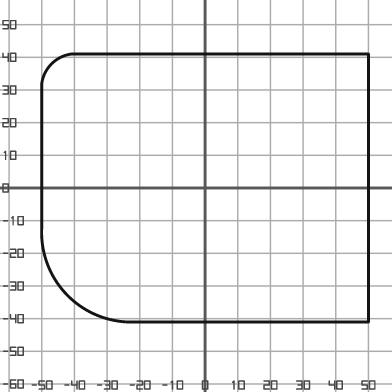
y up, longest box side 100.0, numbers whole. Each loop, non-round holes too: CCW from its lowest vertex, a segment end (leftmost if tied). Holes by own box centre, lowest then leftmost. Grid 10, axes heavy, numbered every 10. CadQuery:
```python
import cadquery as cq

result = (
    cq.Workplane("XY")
    .moveTo(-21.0, -41.0)
    .lineTo(50.0, -41.0)
    .lineTo(50.0, 41.0)
    .lineTo(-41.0, 41.0)
    .threePointArc((-47.0, 38.0), (-50.0, 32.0))
    .lineTo(-50.0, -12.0)
    .threePointArc((-42.0, -33.0), (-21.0, -41.0))
    .close()
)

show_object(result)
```